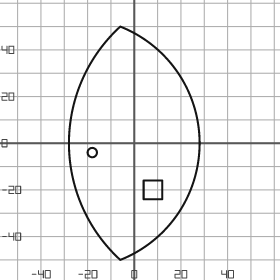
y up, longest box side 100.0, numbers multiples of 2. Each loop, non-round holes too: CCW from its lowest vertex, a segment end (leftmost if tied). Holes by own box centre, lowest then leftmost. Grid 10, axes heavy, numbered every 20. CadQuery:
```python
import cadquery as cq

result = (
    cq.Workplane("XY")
    .moveTo(-6.0, -50.0)
    .threePointArc((28.0, 0.0), (-6.0, 50.0))
    .threePointArc((-28.0, 0.0), (-6.0, -50.0))
    .close()
    .moveTo(4.0, -24.0)
    .lineTo(12.0, -24.0)
    .lineTo(12.0, -16.0)
    .lineTo(4.0, -16.0)
    .close()
    .moveTo(-18.0, -4.0)
    .circle(2.0)
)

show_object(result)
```